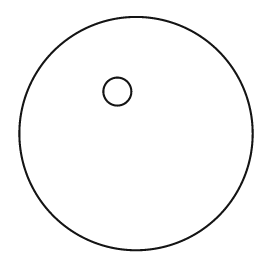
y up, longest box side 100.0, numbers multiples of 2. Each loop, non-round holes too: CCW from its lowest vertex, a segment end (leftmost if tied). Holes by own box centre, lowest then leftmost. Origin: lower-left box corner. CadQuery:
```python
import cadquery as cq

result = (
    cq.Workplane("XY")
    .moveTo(50.0, 50.0)
    .circle(50.0)
    .moveTo(42.0, 68.0)
    .circle(6.0)
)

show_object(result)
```